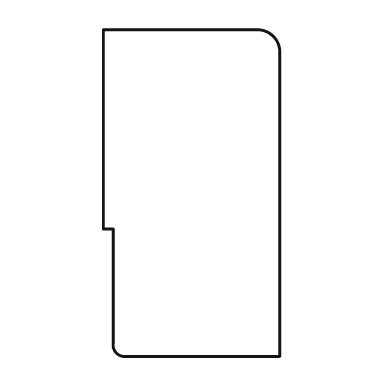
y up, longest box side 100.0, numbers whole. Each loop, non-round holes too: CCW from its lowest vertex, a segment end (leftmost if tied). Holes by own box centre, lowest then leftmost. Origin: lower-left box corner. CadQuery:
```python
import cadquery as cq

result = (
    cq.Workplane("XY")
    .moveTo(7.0, 0.0)
    .lineTo(54.0, 0.0)
    .lineTo(54.0, 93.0)
    .threePointArc((52.0, 98.0), (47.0, 100.0))
    .lineTo(0.0, 100.0)
    .lineTo(0.0, 39.0)
    .lineTo(3.0, 39.0)
    .lineTo(3.0, 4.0)
    .threePointArc((4.0, 1.0), (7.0, 0.0))
    .close()
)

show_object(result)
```